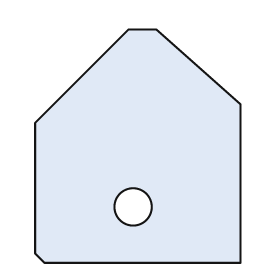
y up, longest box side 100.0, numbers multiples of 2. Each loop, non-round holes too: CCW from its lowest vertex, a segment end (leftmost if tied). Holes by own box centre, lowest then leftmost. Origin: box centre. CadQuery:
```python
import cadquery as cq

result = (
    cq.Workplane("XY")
    .moveTo(-40.0, -50.0)
    .lineTo(44.0, -50.0)
    .lineTo(44.0, 18.0)
    .lineTo(8.0, 50.0)
    .lineTo(-4.0, 50.0)
    .lineTo(-44.0, 10.0)
    .lineTo(-44.0, -46.0)
    .close()
    .moveTo(-2.0, -26.0)
    .circle(8.0)
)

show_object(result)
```